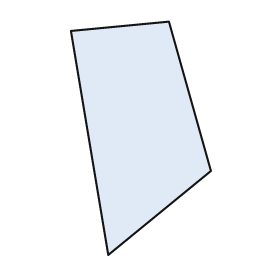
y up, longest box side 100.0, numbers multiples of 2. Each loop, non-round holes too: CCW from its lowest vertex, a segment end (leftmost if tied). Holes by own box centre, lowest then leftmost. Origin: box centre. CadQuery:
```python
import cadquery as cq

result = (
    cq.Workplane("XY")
    .moveTo(-14.0, -50.0)
    .lineTo(30.0, -14.0)
    .lineTo(12.0, 50.0)
    .lineTo(-30.0, 46.0)
    .close()
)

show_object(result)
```